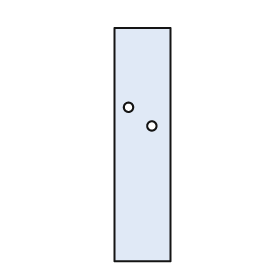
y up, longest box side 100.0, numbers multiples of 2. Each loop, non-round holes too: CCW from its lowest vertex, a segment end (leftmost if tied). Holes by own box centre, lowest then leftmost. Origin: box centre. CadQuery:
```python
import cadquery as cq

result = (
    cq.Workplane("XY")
    .moveTo(-12.0, -50.0)
    .lineTo(12.0, -50.0)
    .lineTo(12.0, 50.0)
    .lineTo(-12.0, 50.0)
    .close()
    .moveTo(4.0, 8.0)
    .circle(2.0)
    .moveTo(-6.0, 16.0)
    .circle(2.0)
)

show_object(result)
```